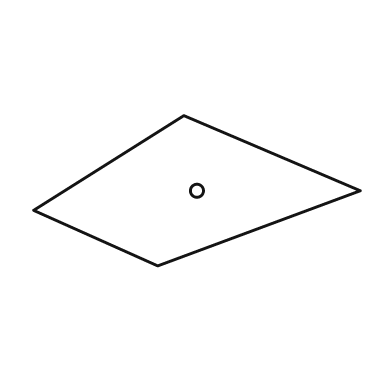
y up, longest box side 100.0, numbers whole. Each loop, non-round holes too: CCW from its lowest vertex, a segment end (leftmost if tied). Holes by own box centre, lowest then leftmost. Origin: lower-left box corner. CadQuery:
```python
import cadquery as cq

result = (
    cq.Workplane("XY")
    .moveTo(38.0, 0.0)
    .lineTo(100.0, 23.0)
    .lineTo(46.0, 46.0)
    .lineTo(0.0, 17.0)
    .close()
    .moveTo(50.0, 23.0)
    .circle(2.0)
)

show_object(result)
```